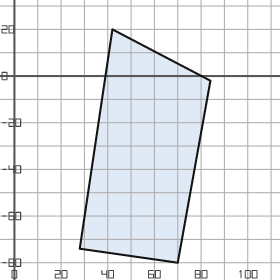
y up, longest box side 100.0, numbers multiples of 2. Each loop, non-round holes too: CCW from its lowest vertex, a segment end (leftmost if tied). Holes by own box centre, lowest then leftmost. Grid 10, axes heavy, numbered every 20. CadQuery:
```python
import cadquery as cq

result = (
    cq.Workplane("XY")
    .moveTo(70.0, -80.0)
    .lineTo(84.0, -2.0)
    .lineTo(42.0, 20.0)
    .lineTo(28.0, -74.0)
    .close()
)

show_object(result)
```